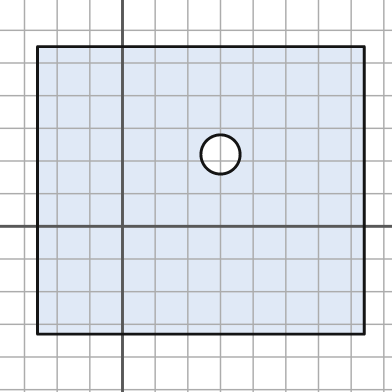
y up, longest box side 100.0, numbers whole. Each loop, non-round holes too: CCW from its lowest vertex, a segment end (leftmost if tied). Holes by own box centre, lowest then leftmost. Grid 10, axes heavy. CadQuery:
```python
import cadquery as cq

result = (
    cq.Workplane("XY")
    .moveTo(-26.0, -33.0)
    .lineTo(74.0, -33.0)
    .lineTo(74.0, 55.0)
    .lineTo(-26.0, 55.0)
    .close()
    .moveTo(30.0, 22.0)
    .circle(6.0)
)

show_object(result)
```